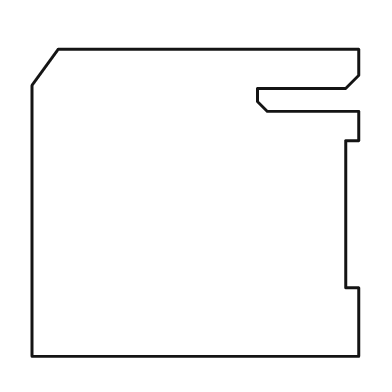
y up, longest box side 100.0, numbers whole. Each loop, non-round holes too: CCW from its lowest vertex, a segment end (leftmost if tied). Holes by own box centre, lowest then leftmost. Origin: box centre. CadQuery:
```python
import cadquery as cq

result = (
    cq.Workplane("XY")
    .moveTo(-50.0, -47.0)
    .lineTo(50.0, -47.0)
    .lineTo(50.0, -26.0)
    .lineTo(46.0, -26.0)
    .lineTo(46.0, 19.0)
    .lineTo(50.0, 19.0)
    .lineTo(50.0, 28.0)
    .lineTo(22.0, 28.0)
    .lineTo(19.0, 31.0)
    .lineTo(19.0, 35.0)
    .lineTo(46.0, 35.0)
    .lineTo(50.0, 39.0)
    .lineTo(50.0, 47.0)
    .lineTo(-42.0, 47.0)
    .lineTo(-50.0, 36.0)
    .close()
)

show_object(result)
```